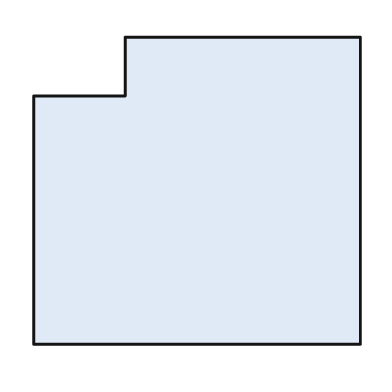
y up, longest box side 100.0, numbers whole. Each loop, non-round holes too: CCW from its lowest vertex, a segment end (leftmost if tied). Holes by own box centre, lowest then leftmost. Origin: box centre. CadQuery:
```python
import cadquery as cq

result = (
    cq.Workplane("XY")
    .moveTo(-50.0, -47.0)
    .lineTo(50.0, -47.0)
    .lineTo(50.0, 47.0)
    .lineTo(-22.0, 47.0)
    .lineTo(-22.0, 29.0)
    .lineTo(-50.0, 29.0)
    .close()
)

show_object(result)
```